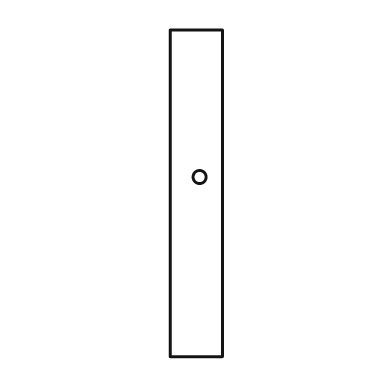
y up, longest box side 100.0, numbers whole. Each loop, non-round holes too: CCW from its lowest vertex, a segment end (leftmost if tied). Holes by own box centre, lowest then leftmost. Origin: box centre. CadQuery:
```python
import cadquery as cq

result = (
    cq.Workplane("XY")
    .moveTo(-8.0, -50.0)
    .lineTo(8.0, -50.0)
    .lineTo(8.0, 50.0)
    .lineTo(-8.0, 50.0)
    .close()
    .moveTo(1.0, 5.0)
    .circle(2.0)
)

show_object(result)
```